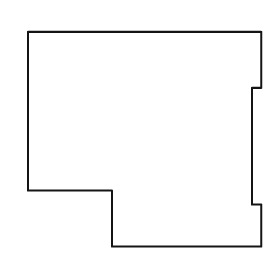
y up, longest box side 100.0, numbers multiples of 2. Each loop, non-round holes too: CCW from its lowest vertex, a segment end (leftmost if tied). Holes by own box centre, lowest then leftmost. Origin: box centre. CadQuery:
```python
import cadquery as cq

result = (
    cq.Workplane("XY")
    .moveTo(-14.0, -46.0)
    .lineTo(50.0, -46.0)
    .lineTo(50.0, -28.0)
    .lineTo(46.0, -28.0)
    .lineTo(46.0, 22.0)
    .lineTo(50.0, 22.0)
    .lineTo(50.0, 46.0)
    .lineTo(-50.0, 46.0)
    .lineTo(-50.0, -22.0)
    .lineTo(-14.0, -22.0)
    .close()
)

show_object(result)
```